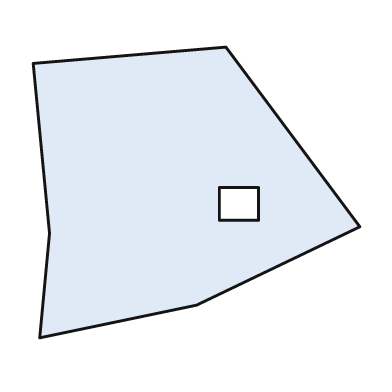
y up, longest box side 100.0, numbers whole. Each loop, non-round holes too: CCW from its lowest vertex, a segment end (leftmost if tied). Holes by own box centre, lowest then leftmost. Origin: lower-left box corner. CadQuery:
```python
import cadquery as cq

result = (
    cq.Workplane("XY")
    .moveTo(2.0, 0.0)
    .lineTo(50.0, 10.0)
    .lineTo(100.0, 34.0)
    .lineTo(59.0, 89.0)
    .lineTo(0.0, 84.0)
    .lineTo(5.0, 32.0)
    .close()
    .moveTo(57.0, 36.0)
    .lineTo(69.0, 36.0)
    .lineTo(69.0, 46.0)
    .lineTo(57.0, 46.0)
    .close()
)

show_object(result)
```